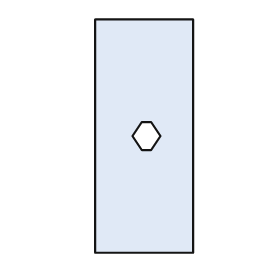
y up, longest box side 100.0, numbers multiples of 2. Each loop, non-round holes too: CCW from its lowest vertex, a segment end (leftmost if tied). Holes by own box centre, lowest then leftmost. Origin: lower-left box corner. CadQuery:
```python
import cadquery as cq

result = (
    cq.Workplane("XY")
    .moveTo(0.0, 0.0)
    .lineTo(42.0, 0.0)
    .lineTo(42.0, 100.0)
    .lineTo(0.0, 100.0)
    .close()
    .moveTo(20.0, 44.0)
    .lineTo(24.0, 44.0)
    .lineTo(28.0, 50.0)
    .lineTo(24.0, 56.0)
    .lineTo(20.0, 56.0)
    .lineTo(16.0, 50.0)
    .close()
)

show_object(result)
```